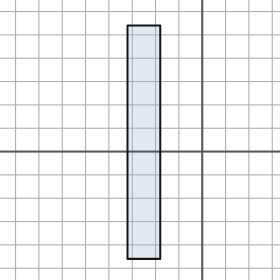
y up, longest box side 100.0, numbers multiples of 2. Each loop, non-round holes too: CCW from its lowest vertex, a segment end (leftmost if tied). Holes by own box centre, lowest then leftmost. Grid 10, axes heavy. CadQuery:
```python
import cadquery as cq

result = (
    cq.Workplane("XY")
    .moveTo(-32.0, -46.0)
    .lineTo(-18.0, -46.0)
    .lineTo(-18.0, 54.0)
    .lineTo(-32.0, 54.0)
    .close()
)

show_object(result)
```